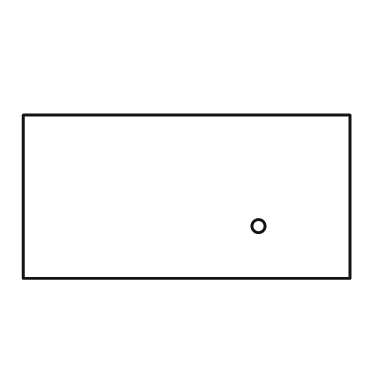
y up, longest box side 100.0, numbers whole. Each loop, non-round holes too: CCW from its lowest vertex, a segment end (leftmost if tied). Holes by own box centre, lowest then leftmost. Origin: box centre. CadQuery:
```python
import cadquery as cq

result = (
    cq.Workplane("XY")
    .moveTo(-50.0, -25.0)
    .lineTo(50.0, -25.0)
    .lineTo(50.0, 25.0)
    .lineTo(-50.0, 25.0)
    .close()
    .moveTo(22.0, -9.0)
    .circle(2.0)
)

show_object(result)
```